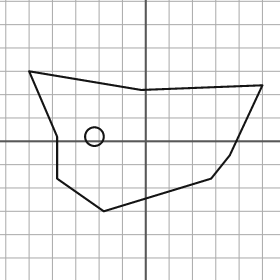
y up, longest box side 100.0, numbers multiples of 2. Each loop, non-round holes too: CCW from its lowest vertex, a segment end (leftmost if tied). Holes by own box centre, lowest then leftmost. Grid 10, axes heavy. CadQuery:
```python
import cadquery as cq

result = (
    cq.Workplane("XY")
    .moveTo(-18.0, -30.0)
    .lineTo(28.0, -16.0)
    .lineTo(36.0, -6.0)
    .lineTo(50.0, 24.0)
    .lineTo(-2.0, 22.0)
    .lineTo(-50.0, 30.0)
    .lineTo(-38.0, 2.0)
    .lineTo(-38.0, -16.0)
    .close()
    .moveTo(-22.0, 2.0)
    .circle(4.0)
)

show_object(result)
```